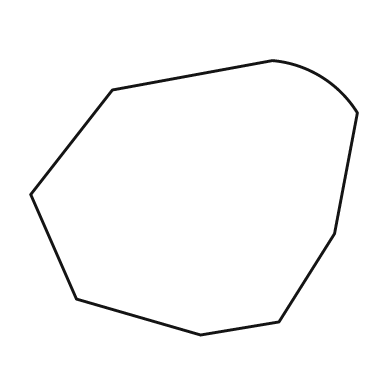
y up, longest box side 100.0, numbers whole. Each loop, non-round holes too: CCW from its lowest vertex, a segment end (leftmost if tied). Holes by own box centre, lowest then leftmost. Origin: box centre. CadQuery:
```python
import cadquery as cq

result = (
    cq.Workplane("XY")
    .moveTo(2.0, -42.0)
    .lineTo(26.0, -38.0)
    .lineTo(43.0, -11.0)
    .lineTo(50.0, 26.0)
    .threePointArc((39.0, 37.0), (24.0, 42.0))
    .lineTo(-25.0, 33.0)
    .lineTo(-50.0, 1.0)
    .lineTo(-36.0, -31.0)
    .close()
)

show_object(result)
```